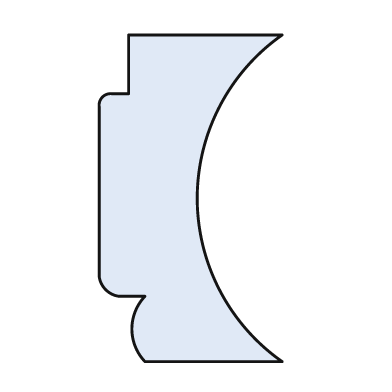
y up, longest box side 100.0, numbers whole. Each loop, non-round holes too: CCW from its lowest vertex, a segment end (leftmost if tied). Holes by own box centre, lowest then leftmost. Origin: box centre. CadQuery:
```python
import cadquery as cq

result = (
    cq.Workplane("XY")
    .moveTo(-14.0, -50.0)
    .lineTo(28.0, -50.0)
    .threePointArc((2.0, 0.0), (28.0, 50.0))
    .lineTo(-19.0, 50.0)
    .lineTo(-19.0, 32.0)
    .lineTo(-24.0, 32.0)
    .threePointArc((-27.0, 31.0), (-28.0, 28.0))
    .lineTo(-28.0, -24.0)
    .threePointArc((-26.0, -28.0), (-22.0, -30.0))
    .lineTo(-14.0, -30.0)
    .threePointArc((-18.0, -40.0), (-14.0, -50.0))
    .close()
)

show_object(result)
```